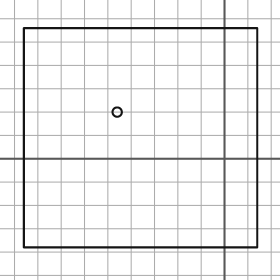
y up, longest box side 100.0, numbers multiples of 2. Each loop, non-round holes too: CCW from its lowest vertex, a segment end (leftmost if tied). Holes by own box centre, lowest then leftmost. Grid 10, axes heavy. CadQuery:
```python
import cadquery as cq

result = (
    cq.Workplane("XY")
    .moveTo(-86.0, -38.0)
    .lineTo(14.0, -38.0)
    .lineTo(14.0, 56.0)
    .lineTo(-86.0, 56.0)
    .close()
    .moveTo(-46.0, 20.0)
    .circle(2.0)
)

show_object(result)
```